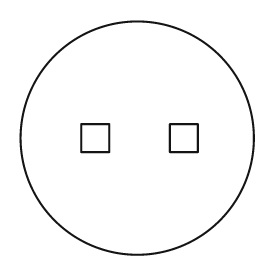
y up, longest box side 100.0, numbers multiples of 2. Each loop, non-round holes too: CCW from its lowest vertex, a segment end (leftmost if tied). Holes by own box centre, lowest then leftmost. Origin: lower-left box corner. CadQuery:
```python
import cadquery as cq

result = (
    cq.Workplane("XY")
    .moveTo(50.0, 50.0)
    .circle(50.0)
    .moveTo(26.0, 44.0)
    .lineTo(38.0, 44.0)
    .lineTo(38.0, 56.0)
    .lineTo(26.0, 56.0)
    .close()
    .moveTo(64.0, 44.0)
    .lineTo(76.0, 44.0)
    .lineTo(76.0, 56.0)
    .lineTo(64.0, 56.0)
    .close()
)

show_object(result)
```